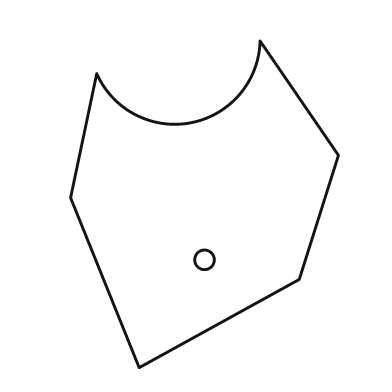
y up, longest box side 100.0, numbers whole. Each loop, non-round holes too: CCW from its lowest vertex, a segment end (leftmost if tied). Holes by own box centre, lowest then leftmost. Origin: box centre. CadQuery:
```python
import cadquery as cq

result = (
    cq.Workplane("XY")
    .moveTo(-20.0, -50.0)
    .lineTo(29.0, -23.0)
    .lineTo(41.0, 15.0)
    .lineTo(17.0, 50.0)
    .threePointArc((-4.0, 25.0), (-33.0, 40.0))
    .lineTo(-41.0, 2.0)
    .close()
    .moveTo(0.0, -17.0)
    .circle(3.0)
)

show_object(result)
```